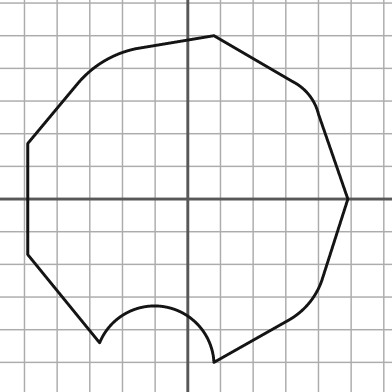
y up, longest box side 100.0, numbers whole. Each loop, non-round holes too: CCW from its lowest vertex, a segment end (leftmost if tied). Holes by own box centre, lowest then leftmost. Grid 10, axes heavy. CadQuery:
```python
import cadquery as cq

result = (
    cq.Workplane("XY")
    .moveTo(8.0, -50.0)
    .lineTo(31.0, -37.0)
    .threePointArc((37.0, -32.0), (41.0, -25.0))
    .lineTo(49.0, 0.0)
    .lineTo(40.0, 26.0)
    .threePointArc((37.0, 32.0), (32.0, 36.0))
    .lineTo(8.0, 50.0)
    .lineTo(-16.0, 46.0)
    .threePointArc((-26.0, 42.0), (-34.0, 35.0))
    .lineTo(-49.0, 17.0)
    .lineTo(-49.0, -17.0)
    .lineTo(-27.0, -44.0)
    .threePointArc((-7.0, -33.0), (8.0, -50.0))
    .close()
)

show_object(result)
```